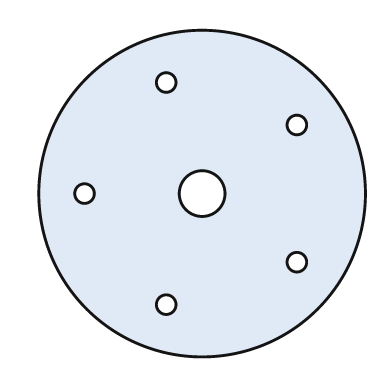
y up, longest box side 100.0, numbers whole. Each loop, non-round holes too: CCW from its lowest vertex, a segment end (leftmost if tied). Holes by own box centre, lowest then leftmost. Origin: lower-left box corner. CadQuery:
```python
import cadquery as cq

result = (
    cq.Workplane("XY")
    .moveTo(50.0, 50.0)
    .circle(50.0)
    .moveTo(39.0, 16.0)
    .circle(3.0)
    .moveTo(79.0, 29.0)
    .circle(3.0)
    .moveTo(14.0, 50.0)
    .circle(3.0)
    .moveTo(50.0, 50.0)
    .circle(7.0)
    .moveTo(79.0, 71.0)
    .circle(3.0)
    .moveTo(39.0, 84.0)
    .circle(3.0)
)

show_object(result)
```